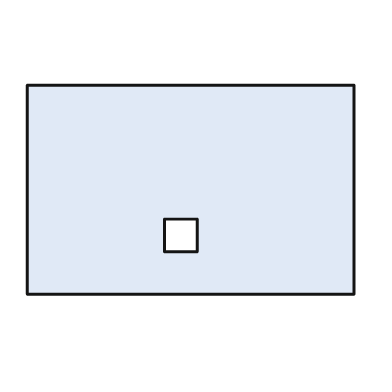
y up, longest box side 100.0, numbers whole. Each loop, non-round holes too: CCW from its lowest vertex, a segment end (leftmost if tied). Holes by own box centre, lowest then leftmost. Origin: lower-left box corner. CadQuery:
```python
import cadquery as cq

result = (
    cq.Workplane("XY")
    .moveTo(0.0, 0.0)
    .lineTo(100.0, 0.0)
    .lineTo(100.0, 64.0)
    .lineTo(0.0, 64.0)
    .close()
    .moveTo(42.0, 13.0)
    .lineTo(52.0, 13.0)
    .lineTo(52.0, 23.0)
    .lineTo(42.0, 23.0)
    .close()
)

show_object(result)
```